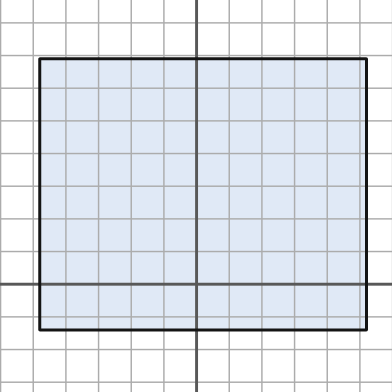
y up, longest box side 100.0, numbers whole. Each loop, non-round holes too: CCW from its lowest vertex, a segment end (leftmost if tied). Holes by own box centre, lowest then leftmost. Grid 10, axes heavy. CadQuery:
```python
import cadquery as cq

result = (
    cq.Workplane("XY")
    .moveTo(-48.0, -14.0)
    .lineTo(52.0, -14.0)
    .lineTo(52.0, 69.0)
    .lineTo(-48.0, 69.0)
    .close()
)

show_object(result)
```